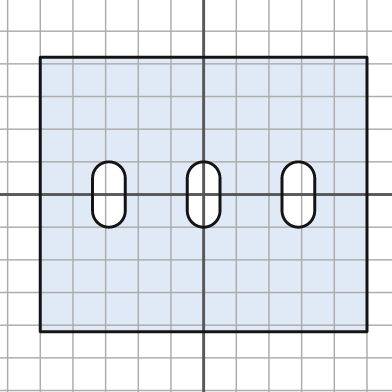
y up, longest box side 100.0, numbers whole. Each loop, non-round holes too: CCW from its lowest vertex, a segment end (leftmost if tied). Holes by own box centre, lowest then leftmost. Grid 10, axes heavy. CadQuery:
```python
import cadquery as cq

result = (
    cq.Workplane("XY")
    .moveTo(-50.0, -42.0)
    .lineTo(50.0, -42.0)
    .lineTo(50.0, 42.0)
    .lineTo(-50.0, 42.0)
    .close()
    .moveTo(-34.0, -5.0)
    .threePointArc((-29.0, -10.0), (-24.0, -5.0))
    .lineTo(-24.0, 5.0)
    .threePointArc((-29.0, 10.0), (-34.0, 5.0))
    .close()
    .moveTo(-5.0, -5.0)
    .threePointArc((0.0, -10.0), (5.0, -5.0))
    .lineTo(5.0, 5.0)
    .threePointArc((0.0, 10.0), (-5.0, 5.0))
    .close()
    .moveTo(24.0, -5.0)
    .threePointArc((29.0, -10.0), (34.0, -5.0))
    .lineTo(34.0, 5.0)
    .threePointArc((29.0, 10.0), (24.0, 5.0))
    .close()
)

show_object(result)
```